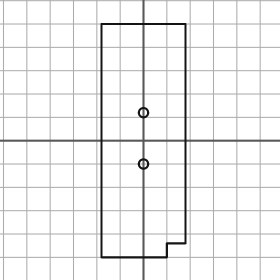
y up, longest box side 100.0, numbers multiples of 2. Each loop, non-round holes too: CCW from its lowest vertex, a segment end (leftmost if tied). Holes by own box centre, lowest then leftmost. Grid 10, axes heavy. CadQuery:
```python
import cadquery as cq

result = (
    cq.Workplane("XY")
    .moveTo(-18.0, -50.0)
    .lineTo(10.0, -50.0)
    .lineTo(10.0, -44.0)
    .lineTo(18.0, -44.0)
    .lineTo(18.0, 50.0)
    .lineTo(-18.0, 50.0)
    .close()
    .moveTo(0.0, -10.0)
    .circle(2.0)
    .moveTo(0.0, 12.0)
    .circle(2.0)
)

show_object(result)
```